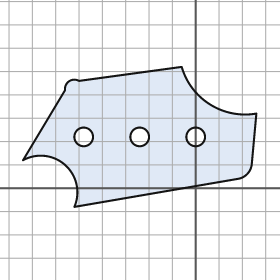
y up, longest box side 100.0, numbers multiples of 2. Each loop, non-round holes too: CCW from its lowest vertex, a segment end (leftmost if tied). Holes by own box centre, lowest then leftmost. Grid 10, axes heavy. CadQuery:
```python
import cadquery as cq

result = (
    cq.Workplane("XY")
    .moveTo(-52.0, -8.0)
    .lineTo(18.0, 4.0)
    .threePointArc((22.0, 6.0), (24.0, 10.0))
    .lineTo(26.0, 32.0)
    .threePointArc((6.0, 36.0), (-6.0, 52.0))
    .lineTo(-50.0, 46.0)
    .threePointArc((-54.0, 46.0), (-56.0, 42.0))
    .lineTo(-74.0, 12.0)
    .threePointArc((-56.0, 10.0), (-52.0, -8.0))
    .close()
    .moveTo(-48.0, 22.0)
    .circle(4.0)
    .moveTo(-24.0, 22.0)
    .circle(4.0)
    .moveTo(0.0, 22.0)
    .circle(4.0)
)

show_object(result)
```